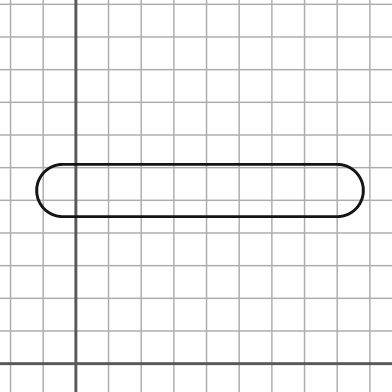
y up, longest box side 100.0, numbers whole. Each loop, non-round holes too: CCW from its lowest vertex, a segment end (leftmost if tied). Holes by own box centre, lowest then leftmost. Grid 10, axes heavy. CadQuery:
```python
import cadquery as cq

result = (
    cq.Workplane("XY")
    .moveTo(-4.0, 45.0)
    .lineTo(80.0, 45.0)
    .threePointArc((88.0, 53.0), (80.0, 61.0))
    .lineTo(-4.0, 61.0)
    .threePointArc((-12.0, 53.0), (-4.0, 45.0))
    .close()
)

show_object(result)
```